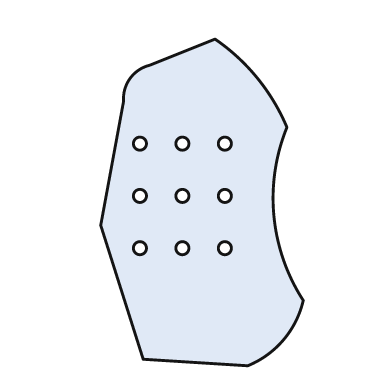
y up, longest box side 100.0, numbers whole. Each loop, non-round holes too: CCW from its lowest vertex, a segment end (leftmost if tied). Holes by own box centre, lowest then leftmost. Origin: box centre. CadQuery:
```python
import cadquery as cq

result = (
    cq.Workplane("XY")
    .moveTo(14.0, -50.0)
    .threePointArc((25.0, -42.0), (31.0, -30.0))
    .threePointArc((22.0, -4.0), (26.0, 23.0))
    .threePointArc((17.0, 38.0), (4.0, 50.0))
    .lineTo(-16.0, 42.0)
    .threePointArc((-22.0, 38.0), (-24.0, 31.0))
    .lineTo(-31.0, -7.0)
    .lineTo(-18.0, -48.0)
    .close()
    .moveTo(-19.0, -14.0)
    .circle(2.0)
    .moveTo(-6.0, -14.0)
    .circle(2.0)
    .moveTo(7.0, -14.0)
    .circle(2.0)
    .moveTo(-19.0, 2.0)
    .circle(2.0)
    .moveTo(-6.0, 2.0)
    .circle(2.0)
    .moveTo(7.0, 2.0)
    .circle(2.0)
    .moveTo(-19.0, 18.0)
    .circle(2.0)
    .moveTo(-6.0, 18.0)
    .circle(2.0)
    .moveTo(7.0, 18.0)
    .circle(2.0)
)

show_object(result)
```